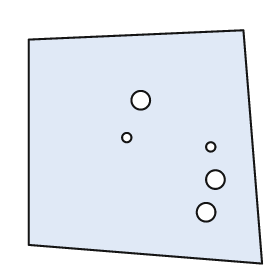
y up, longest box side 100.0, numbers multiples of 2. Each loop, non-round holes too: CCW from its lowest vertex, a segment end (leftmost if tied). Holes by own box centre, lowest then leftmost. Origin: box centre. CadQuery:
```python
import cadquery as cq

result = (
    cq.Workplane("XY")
    .moveTo(50.0, -50.0)
    .lineTo(42.0, 50.0)
    .lineTo(-50.0, 46.0)
    .lineTo(-50.0, -42.0)
    .close()
    .moveTo(26.0, -28.0)
    .circle(4.0)
    .moveTo(30.0, -14.0)
    .circle(4.0)
    .moveTo(28.0, 0.0)
    .circle(2.0)
    .moveTo(-8.0, 4.0)
    .circle(2.0)
    .moveTo(-2.0, 20.0)
    .circle(4.0)
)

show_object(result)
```